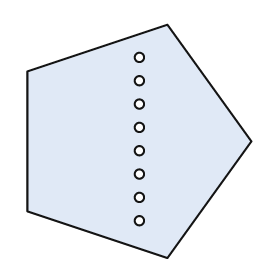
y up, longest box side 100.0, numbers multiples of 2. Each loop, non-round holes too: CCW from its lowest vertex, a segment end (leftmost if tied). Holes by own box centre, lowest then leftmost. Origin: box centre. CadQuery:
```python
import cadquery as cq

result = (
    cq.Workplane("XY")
    .moveTo(12.0, -50.0)
    .lineTo(48.0, 0.0)
    .lineTo(12.0, 50.0)
    .lineTo(-48.0, 30.0)
    .lineTo(-48.0, -30.0)
    .close()
    .moveTo(0.0, -34.0)
    .circle(2.0)
    .moveTo(0.0, -24.0)
    .circle(2.0)
    .moveTo(0.0, -14.0)
    .circle(2.0)
    .moveTo(0.0, -4.0)
    .circle(2.0)
    .moveTo(0.0, 6.0)
    .circle(2.0)
    .moveTo(0.0, 16.0)
    .circle(2.0)
    .moveTo(0.0, 26.0)
    .circle(2.0)
    .moveTo(0.0, 36.0)
    .circle(2.0)
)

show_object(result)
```